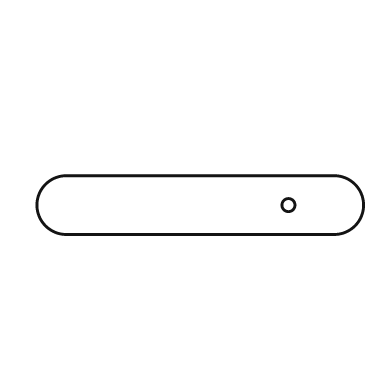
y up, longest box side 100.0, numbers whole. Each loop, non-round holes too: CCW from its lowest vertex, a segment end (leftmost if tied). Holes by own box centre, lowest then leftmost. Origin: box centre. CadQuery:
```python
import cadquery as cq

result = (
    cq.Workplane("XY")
    .moveTo(-41.0, -9.0)
    .lineTo(41.0, -9.0)
    .threePointArc((50.0, 0.0), (41.0, 9.0))
    .lineTo(-41.0, 9.0)
    .threePointArc((-50.0, 0.0), (-41.0, -9.0))
    .close()
    .moveTo(27.0, 0.0)
    .circle(2.0)
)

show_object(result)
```